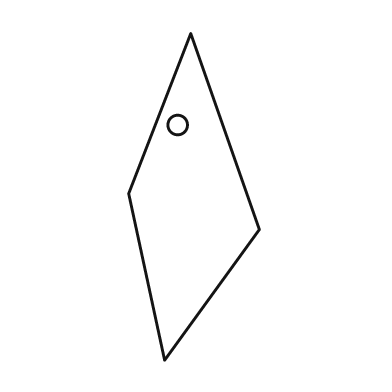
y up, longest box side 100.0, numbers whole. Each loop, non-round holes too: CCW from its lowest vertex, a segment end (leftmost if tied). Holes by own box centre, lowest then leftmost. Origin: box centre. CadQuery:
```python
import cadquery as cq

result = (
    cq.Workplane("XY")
    .moveTo(-9.0, -50.0)
    .lineTo(20.0, -10.0)
    .lineTo(-1.0, 50.0)
    .lineTo(-20.0, 1.0)
    .close()
    .moveTo(-5.0, 22.0)
    .circle(3.0)
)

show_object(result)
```